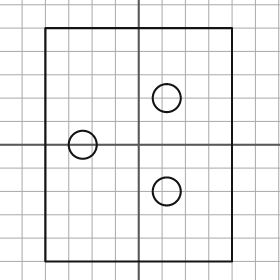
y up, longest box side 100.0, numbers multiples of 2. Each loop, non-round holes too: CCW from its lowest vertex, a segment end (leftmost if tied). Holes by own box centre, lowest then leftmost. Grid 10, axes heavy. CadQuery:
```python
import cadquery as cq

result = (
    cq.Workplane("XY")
    .moveTo(-40.0, -50.0)
    .lineTo(40.0, -50.0)
    .lineTo(40.0, 50.0)
    .lineTo(-40.0, 50.0)
    .close()
    .moveTo(12.0, -20.0)
    .circle(6.0)
    .moveTo(-24.0, 0.0)
    .circle(6.0)
    .moveTo(12.0, 20.0)
    .circle(6.0)
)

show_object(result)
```